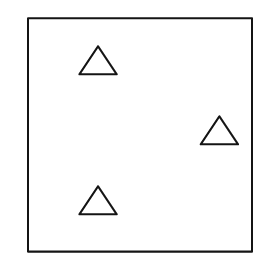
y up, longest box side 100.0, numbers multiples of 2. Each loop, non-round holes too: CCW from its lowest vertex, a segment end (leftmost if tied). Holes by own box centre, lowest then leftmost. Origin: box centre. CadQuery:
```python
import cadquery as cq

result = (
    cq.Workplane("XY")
    .moveTo(-48.0, -50.0)
    .lineTo(48.0, -50.0)
    .lineTo(48.0, 50.0)
    .lineTo(-48.0, 50.0)
    .close()
    .moveTo(-26.0, -34.0)
    .lineTo(-10.0, -34.0)
    .lineTo(-18.0, -22.0)
    .close()
    .moveTo(26.0, -4.0)
    .lineTo(42.0, -4.0)
    .lineTo(34.0, 8.0)
    .close()
    .moveTo(-26.0, 26.0)
    .lineTo(-10.0, 26.0)
    .lineTo(-18.0, 38.0)
    .close()
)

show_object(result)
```